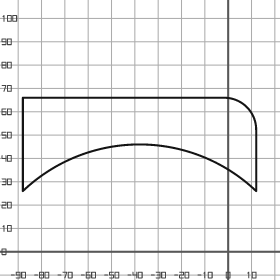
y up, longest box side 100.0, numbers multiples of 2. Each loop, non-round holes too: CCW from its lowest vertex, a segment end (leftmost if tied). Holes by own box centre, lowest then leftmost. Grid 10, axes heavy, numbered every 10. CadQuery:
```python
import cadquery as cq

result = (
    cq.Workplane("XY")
    .moveTo(-88.0, 26.0)
    .threePointArc((-38.0, 46.0), (12.0, 26.0))
    .lineTo(12.0, 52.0)
    .threePointArc((8.0, 62.0), (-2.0, 66.0))
    .lineTo(-88.0, 66.0)
    .close()
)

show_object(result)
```